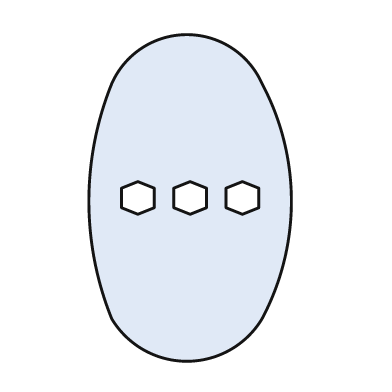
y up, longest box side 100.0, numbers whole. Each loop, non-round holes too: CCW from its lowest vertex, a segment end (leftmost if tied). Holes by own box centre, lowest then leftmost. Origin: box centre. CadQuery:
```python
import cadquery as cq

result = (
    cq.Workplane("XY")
    .moveTo(-24.0, -37.0)
    .threePointArc((-1.0, -50.0), (22.0, -37.0))
    .threePointArc((31.0, -1.0), (22.0, 35.0))
    .threePointArc((-1.0, 50.0), (-24.0, 35.0))
    .threePointArc((-31.0, -1.0), (-24.0, -37.0))
    .close()
    .moveTo(-16.0, -5.0)
    .lineTo(-11.0, -3.0)
    .lineTo(-11.0, 3.0)
    .lineTo(-16.0, 5.0)
    .lineTo(-21.0, 3.0)
    .lineTo(-21.0, -3.0)
    .close()
    .moveTo(0.0, -5.0)
    .lineTo(5.0, -3.0)
    .lineTo(5.0, 3.0)
    .lineTo(0.0, 5.0)
    .lineTo(-5.0, 3.0)
    .lineTo(-5.0, -3.0)
    .close()
    .moveTo(16.0, -5.0)
    .lineTo(21.0, -3.0)
    .lineTo(21.0, 3.0)
    .lineTo(16.0, 5.0)
    .lineTo(11.0, 3.0)
    .lineTo(11.0, -3.0)
    .close()
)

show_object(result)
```